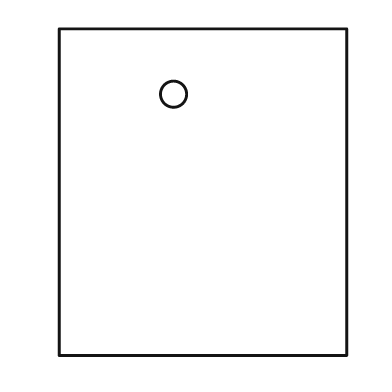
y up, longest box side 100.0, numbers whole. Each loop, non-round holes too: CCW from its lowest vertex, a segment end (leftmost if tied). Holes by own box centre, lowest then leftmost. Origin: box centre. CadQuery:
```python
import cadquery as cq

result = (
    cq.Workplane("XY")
    .moveTo(-44.0, -50.0)
    .lineTo(44.0, -50.0)
    .lineTo(44.0, 50.0)
    .lineTo(-44.0, 50.0)
    .close()
    .moveTo(-9.0, 30.0)
    .circle(4.0)
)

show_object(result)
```